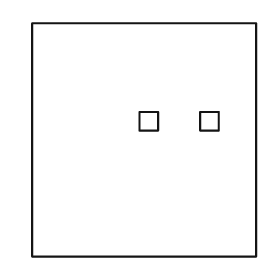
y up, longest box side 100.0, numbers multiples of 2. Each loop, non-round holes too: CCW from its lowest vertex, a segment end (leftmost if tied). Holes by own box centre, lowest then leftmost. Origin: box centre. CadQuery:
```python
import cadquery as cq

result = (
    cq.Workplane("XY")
    .moveTo(-48.0, -50.0)
    .lineTo(48.0, -50.0)
    .lineTo(48.0, 50.0)
    .lineTo(-48.0, 50.0)
    .close()
    .moveTo(-2.0, 4.0)
    .lineTo(6.0, 4.0)
    .lineTo(6.0, 12.0)
    .lineTo(-2.0, 12.0)
    .close()
    .moveTo(24.0, 4.0)
    .lineTo(32.0, 4.0)
    .lineTo(32.0, 12.0)
    .lineTo(24.0, 12.0)
    .close()
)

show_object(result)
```